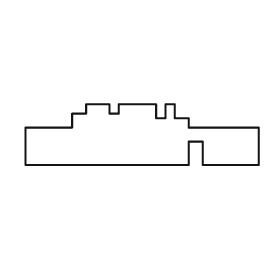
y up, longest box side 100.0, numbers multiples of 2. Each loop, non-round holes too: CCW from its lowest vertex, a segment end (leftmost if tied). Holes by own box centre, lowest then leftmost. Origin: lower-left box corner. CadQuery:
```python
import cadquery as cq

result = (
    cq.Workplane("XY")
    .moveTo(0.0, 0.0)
    .lineTo(70.0, 0.0)
    .lineTo(70.0, 10.0)
    .lineTo(76.0, 10.0)
    .lineTo(76.0, 0.0)
    .lineTo(100.0, 0.0)
    .lineTo(100.0, 16.0)
    .lineTo(70.0, 16.0)
    .lineTo(70.0, 20.0)
    .lineTo(64.0, 20.0)
    .lineTo(64.0, 26.0)
    .lineTo(60.0, 26.0)
    .lineTo(60.0, 20.0)
    .lineTo(56.0, 20.0)
    .lineTo(56.0, 26.0)
    .lineTo(40.0, 26.0)
    .lineTo(40.0, 22.0)
    .lineTo(36.0, 22.0)
    .lineTo(36.0, 26.0)
    .lineTo(26.0, 26.0)
    .lineTo(26.0, 22.0)
    .lineTo(20.0, 22.0)
    .lineTo(20.0, 16.0)
    .lineTo(0.0, 16.0)
    .close()
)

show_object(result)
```